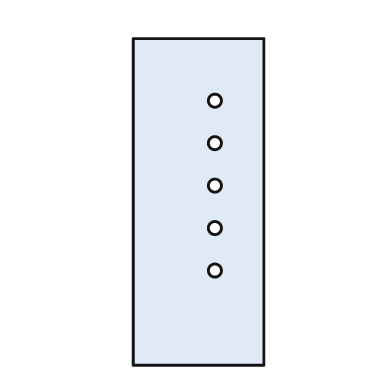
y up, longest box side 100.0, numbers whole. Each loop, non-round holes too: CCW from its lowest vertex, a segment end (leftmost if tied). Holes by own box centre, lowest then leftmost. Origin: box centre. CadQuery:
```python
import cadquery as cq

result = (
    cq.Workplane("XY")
    .moveTo(-20.0, -50.0)
    .lineTo(20.0, -50.0)
    .lineTo(20.0, 50.0)
    .lineTo(-20.0, 50.0)
    .close()
    .moveTo(5.0, -21.0)
    .circle(2.0)
    .moveTo(5.0, -8.0)
    .circle(2.0)
    .moveTo(5.0, 5.0)
    .circle(2.0)
    .moveTo(5.0, 18.0)
    .circle(2.0)
    .moveTo(5.0, 31.0)
    .circle(2.0)
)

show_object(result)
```